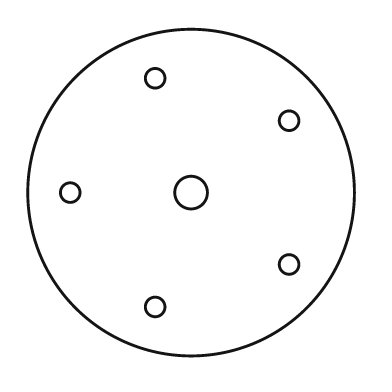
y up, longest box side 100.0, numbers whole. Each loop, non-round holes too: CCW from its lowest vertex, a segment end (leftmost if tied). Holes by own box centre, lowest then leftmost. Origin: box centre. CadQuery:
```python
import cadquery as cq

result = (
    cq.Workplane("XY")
    .moveTo(0.0, 0.0)
    .circle(50.0)
    .moveTo(-11.0, -35.0)
    .circle(3.0)
    .moveTo(30.0, -22.0)
    .circle(3.0)
    .moveTo(-37.0, 0.0)
    .circle(3.0)
    .moveTo(0.0, 0.0)
    .circle(5.0)
    .moveTo(30.0, 22.0)
    .circle(3.0)
    .moveTo(-11.0, 35.0)
    .circle(3.0)
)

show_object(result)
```